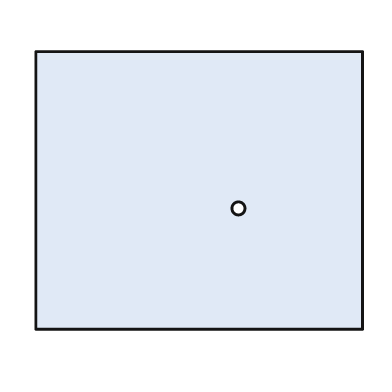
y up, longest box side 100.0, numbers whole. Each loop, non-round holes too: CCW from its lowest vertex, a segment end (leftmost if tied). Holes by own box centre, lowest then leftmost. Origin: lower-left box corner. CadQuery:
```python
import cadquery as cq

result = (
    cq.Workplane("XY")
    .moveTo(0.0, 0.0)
    .lineTo(100.0, 0.0)
    .lineTo(100.0, 85.0)
    .lineTo(0.0, 85.0)
    .close()
    .moveTo(62.0, 37.0)
    .circle(2.0)
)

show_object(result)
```